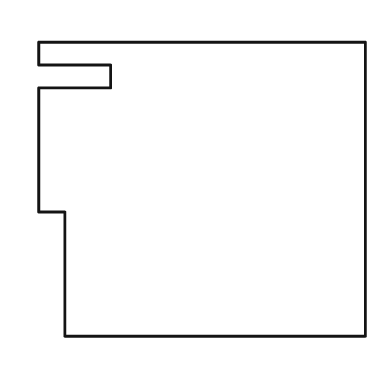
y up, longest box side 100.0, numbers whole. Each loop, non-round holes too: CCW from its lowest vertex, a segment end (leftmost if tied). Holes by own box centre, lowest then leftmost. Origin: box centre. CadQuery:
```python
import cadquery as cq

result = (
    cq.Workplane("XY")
    .moveTo(-42.0, -45.0)
    .lineTo(50.0, -45.0)
    .lineTo(50.0, 45.0)
    .lineTo(-50.0, 45.0)
    .lineTo(-50.0, 38.0)
    .lineTo(-28.0, 38.0)
    .lineTo(-28.0, 31.0)
    .lineTo(-50.0, 31.0)
    .lineTo(-50.0, -7.0)
    .lineTo(-42.0, -7.0)
    .close()
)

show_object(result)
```